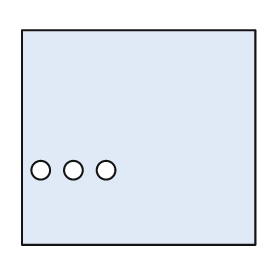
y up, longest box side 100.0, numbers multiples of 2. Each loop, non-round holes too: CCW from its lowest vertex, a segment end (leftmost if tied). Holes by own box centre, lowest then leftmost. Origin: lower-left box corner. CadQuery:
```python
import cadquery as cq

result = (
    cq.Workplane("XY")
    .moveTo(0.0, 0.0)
    .lineTo(100.0, 0.0)
    .lineTo(100.0, 92.0)
    .lineTo(0.0, 92.0)
    .close()
    .moveTo(8.0, 32.0)
    .circle(4.0)
    .moveTo(22.0, 32.0)
    .circle(4.0)
    .moveTo(36.0, 32.0)
    .circle(4.0)
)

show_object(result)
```